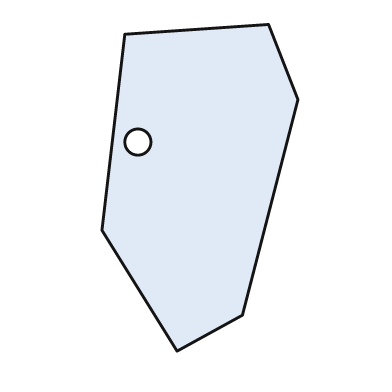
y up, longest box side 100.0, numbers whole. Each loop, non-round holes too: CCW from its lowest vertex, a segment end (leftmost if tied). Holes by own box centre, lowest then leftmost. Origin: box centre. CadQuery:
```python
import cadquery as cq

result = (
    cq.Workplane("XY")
    .moveTo(-7.0, -50.0)
    .lineTo(13.0, -39.0)
    .lineTo(30.0, 27.0)
    .lineTo(21.0, 50.0)
    .lineTo(-23.0, 47.0)
    .lineTo(-30.0, -13.0)
    .close()
    .moveTo(-19.0, 14.0)
    .circle(4.0)
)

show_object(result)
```